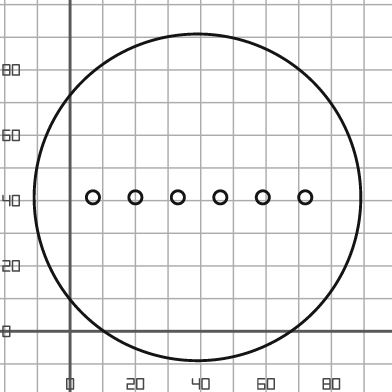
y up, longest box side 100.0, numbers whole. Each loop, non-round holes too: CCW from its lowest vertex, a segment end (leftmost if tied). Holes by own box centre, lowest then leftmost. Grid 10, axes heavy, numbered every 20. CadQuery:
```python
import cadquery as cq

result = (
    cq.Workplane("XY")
    .moveTo(39.0, 41.0)
    .circle(50.0)
    .moveTo(7.0, 41.0)
    .circle(2.0)
    .moveTo(20.0, 41.0)
    .circle(2.0)
    .moveTo(33.0, 41.0)
    .circle(2.0)
    .moveTo(46.0, 41.0)
    .circle(2.0)
    .moveTo(59.0, 41.0)
    .circle(2.0)
    .moveTo(72.0, 41.0)
    .circle(2.0)
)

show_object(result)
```